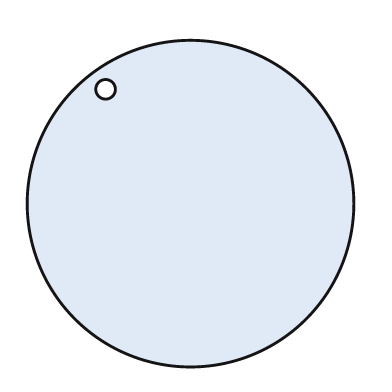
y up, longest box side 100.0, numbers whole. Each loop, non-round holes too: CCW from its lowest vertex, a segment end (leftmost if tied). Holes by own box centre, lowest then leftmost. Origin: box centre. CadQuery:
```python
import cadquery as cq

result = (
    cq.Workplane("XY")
    .moveTo(0.0, 0.0)
    .circle(50.0)
    .moveTo(-26.0, 35.0)
    .circle(3.0)
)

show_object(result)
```